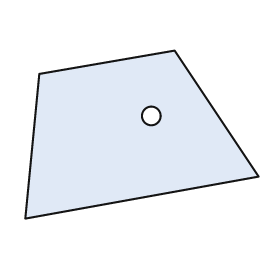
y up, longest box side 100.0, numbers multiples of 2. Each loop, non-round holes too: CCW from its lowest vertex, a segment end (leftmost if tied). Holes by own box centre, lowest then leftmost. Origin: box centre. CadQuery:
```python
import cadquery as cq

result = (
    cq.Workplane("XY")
    .moveTo(-50.0, -36.0)
    .lineTo(50.0, -18.0)
    .lineTo(14.0, 36.0)
    .lineTo(-44.0, 26.0)
    .close()
    .moveTo(4.0, 8.0)
    .circle(4.0)
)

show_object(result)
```